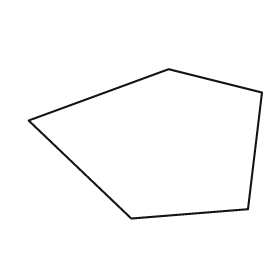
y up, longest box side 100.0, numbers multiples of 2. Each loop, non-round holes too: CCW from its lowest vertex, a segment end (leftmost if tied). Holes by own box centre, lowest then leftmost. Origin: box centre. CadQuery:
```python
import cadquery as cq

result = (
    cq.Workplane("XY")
    .moveTo(-6.0, -32.0)
    .lineTo(44.0, -28.0)
    .lineTo(50.0, 22.0)
    .lineTo(10.0, 32.0)
    .lineTo(-50.0, 10.0)
    .close()
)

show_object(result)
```